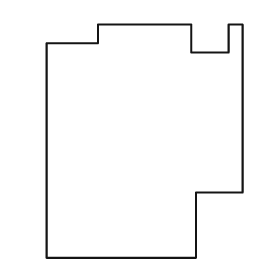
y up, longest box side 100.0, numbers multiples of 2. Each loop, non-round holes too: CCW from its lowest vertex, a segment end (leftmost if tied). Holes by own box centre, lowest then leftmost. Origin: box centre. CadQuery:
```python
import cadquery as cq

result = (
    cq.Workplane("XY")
    .moveTo(-42.0, -50.0)
    .lineTo(22.0, -50.0)
    .lineTo(22.0, -22.0)
    .lineTo(42.0, -22.0)
    .lineTo(42.0, 50.0)
    .lineTo(36.0, 50.0)
    .lineTo(36.0, 38.0)
    .lineTo(20.0, 38.0)
    .lineTo(20.0, 50.0)
    .lineTo(-20.0, 50.0)
    .lineTo(-20.0, 42.0)
    .lineTo(-42.0, 42.0)
    .close()
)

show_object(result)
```